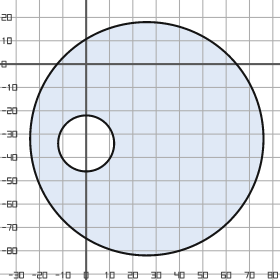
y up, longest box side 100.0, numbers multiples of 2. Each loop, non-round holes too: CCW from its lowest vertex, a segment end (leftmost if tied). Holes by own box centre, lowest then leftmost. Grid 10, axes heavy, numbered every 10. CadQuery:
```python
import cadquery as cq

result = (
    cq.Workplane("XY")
    .moveTo(26.0, -32.0)
    .circle(50.0)
    .moveTo(0.0, -34.0)
    .circle(12.0)
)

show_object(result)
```